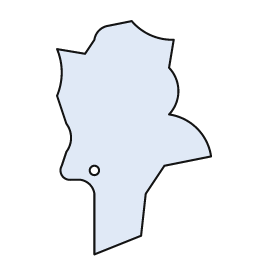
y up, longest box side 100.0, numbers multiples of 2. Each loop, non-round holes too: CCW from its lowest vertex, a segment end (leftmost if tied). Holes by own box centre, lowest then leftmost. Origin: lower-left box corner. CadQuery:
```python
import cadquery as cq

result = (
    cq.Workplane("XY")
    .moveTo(16.0, 0.0)
    .lineTo(36.0, 8.0)
    .lineTo(38.0, 26.0)
    .lineTo(46.0, 38.0)
    .lineTo(66.0, 42.0)
    .threePointArc((60.0, 54.0), (48.0, 60.0))
    .threePointArc((52.0, 70.0), (48.0, 80.0))
    .lineTo(50.0, 92.0)
    .threePointArc((40.0, 94.0), (32.0, 100.0))
    .lineTo(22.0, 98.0)
    .threePointArc((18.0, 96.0), (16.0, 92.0))
    .lineTo(12.0, 86.0)
    .lineTo(0.0, 88.0)
    .threePointArc((2.0, 78.0), (0.0, 68.0))
    .lineTo(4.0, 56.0)
    .threePointArc((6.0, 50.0), (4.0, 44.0))
    .lineTo(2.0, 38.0)
    .threePointArc((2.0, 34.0), (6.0, 32.0))
    .lineTo(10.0, 32.0)
    .threePointArc((14.0, 30.0), (16.0, 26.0))
    .close()
    .moveTo(16.0, 36.0)
    .circle(2.0)
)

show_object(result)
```